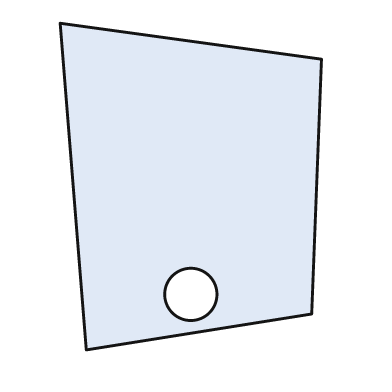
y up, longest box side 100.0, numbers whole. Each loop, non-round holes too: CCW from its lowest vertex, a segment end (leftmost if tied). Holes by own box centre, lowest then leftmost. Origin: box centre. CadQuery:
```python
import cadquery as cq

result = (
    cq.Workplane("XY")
    .moveTo(-32.0, -50.0)
    .lineTo(37.0, -39.0)
    .lineTo(40.0, 39.0)
    .lineTo(-40.0, 50.0)
    .close()
    .moveTo(0.0, -33.0)
    .circle(8.0)
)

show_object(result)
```